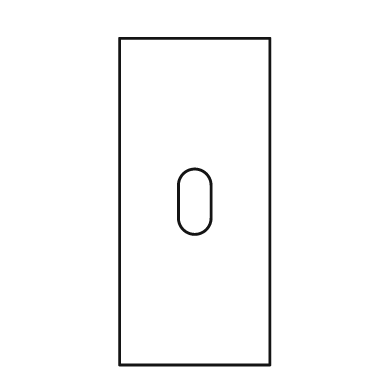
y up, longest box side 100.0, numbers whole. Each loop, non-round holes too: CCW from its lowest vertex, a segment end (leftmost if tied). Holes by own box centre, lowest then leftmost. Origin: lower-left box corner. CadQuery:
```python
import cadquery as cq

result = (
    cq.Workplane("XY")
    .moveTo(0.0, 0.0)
    .lineTo(46.0, 0.0)
    .lineTo(46.0, 100.0)
    .lineTo(0.0, 100.0)
    .close()
    .moveTo(18.0, 45.0)
    .threePointArc((23.0, 40.0), (28.0, 45.0))
    .lineTo(28.0, 55.0)
    .threePointArc((23.0, 60.0), (18.0, 55.0))
    .close()
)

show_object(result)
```